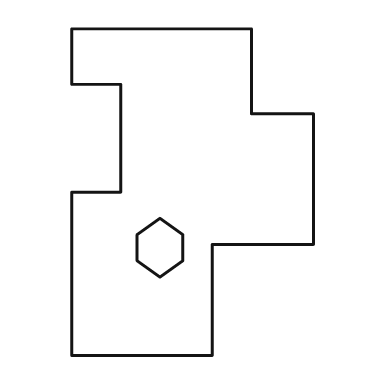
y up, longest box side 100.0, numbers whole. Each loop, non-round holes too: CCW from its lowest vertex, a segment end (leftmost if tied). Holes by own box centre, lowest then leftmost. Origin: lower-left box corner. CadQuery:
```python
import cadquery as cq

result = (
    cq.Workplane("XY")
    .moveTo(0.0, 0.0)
    .lineTo(43.0, 0.0)
    .lineTo(43.0, 34.0)
    .lineTo(74.0, 34.0)
    .lineTo(74.0, 74.0)
    .lineTo(55.0, 74.0)
    .lineTo(55.0, 100.0)
    .lineTo(0.0, 100.0)
    .lineTo(0.0, 83.0)
    .lineTo(15.0, 83.0)
    .lineTo(15.0, 50.0)
    .lineTo(0.0, 50.0)
    .close()
    .moveTo(27.0, 24.0)
    .lineTo(34.0, 29.0)
    .lineTo(34.0, 37.0)
    .lineTo(27.0, 42.0)
    .lineTo(20.0, 37.0)
    .lineTo(20.0, 29.0)
    .close()
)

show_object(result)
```